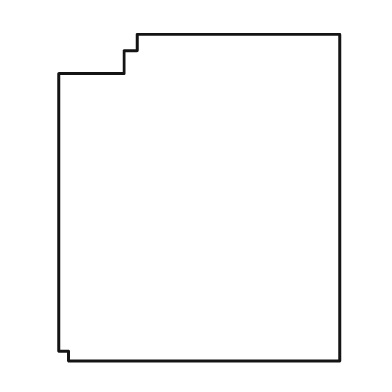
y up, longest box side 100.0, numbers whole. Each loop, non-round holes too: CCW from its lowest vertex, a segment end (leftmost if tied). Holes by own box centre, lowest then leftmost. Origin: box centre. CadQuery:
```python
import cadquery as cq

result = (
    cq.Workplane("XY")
    .moveTo(-40.0, -50.0)
    .lineTo(43.0, -50.0)
    .lineTo(43.0, 50.0)
    .lineTo(-19.0, 50.0)
    .lineTo(-19.0, 45.0)
    .lineTo(-23.0, 45.0)
    .lineTo(-23.0, 38.0)
    .lineTo(-43.0, 38.0)
    .lineTo(-43.0, -47.0)
    .lineTo(-40.0, -47.0)
    .close()
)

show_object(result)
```